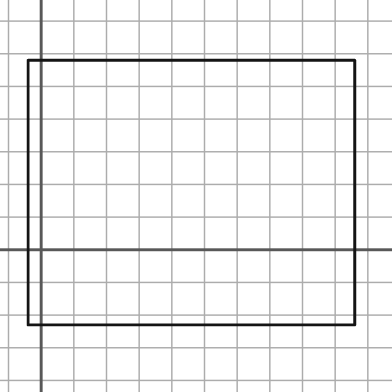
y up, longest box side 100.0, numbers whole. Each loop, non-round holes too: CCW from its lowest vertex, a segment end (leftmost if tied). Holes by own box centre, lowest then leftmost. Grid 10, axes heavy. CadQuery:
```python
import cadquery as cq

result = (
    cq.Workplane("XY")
    .moveTo(-4.0, -23.0)
    .lineTo(96.0, -23.0)
    .lineTo(96.0, 58.0)
    .lineTo(-4.0, 58.0)
    .close()
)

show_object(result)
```